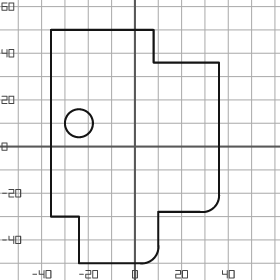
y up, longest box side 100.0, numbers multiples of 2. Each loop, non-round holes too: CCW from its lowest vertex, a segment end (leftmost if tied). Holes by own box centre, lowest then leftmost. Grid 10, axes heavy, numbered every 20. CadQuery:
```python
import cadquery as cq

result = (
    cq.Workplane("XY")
    .moveTo(-24.0, -50.0)
    .lineTo(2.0, -50.0)
    .threePointArc((8.0, -48.0), (10.0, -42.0))
    .lineTo(10.0, -28.0)
    .lineTo(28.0, -28.0)
    .threePointArc((34.0, -26.0), (36.0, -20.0))
    .lineTo(36.0, 36.0)
    .lineTo(8.0, 36.0)
    .lineTo(8.0, 50.0)
    .lineTo(-36.0, 50.0)
    .lineTo(-36.0, -30.0)
    .lineTo(-24.0, -30.0)
    .close()
    .moveTo(-24.0, 10.0)
    .circle(6.0)
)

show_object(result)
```